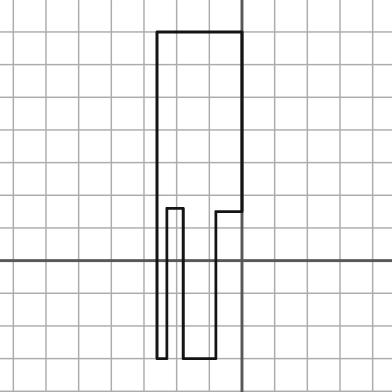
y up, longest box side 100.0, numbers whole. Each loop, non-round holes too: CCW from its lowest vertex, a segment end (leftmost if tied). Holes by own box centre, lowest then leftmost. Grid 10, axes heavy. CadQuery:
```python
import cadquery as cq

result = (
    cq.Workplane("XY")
    .moveTo(-26.0, -30.0)
    .lineTo(-23.0, -30.0)
    .lineTo(-23.0, 16.0)
    .lineTo(-18.0, 16.0)
    .lineTo(-18.0, -30.0)
    .lineTo(-8.0, -30.0)
    .lineTo(-8.0, 15.0)
    .lineTo(0.0, 15.0)
    .lineTo(0.0, 70.0)
    .lineTo(-26.0, 70.0)
    .close()
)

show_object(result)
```